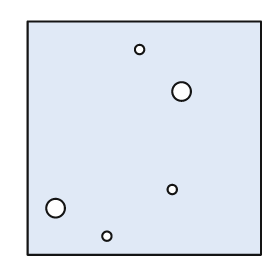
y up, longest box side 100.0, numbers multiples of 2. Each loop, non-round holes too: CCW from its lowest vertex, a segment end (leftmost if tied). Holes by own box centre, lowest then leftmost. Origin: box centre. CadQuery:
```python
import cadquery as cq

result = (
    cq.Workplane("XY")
    .moveTo(-50.0, -50.0)
    .lineTo(50.0, -50.0)
    .lineTo(50.0, 50.0)
    .lineTo(-50.0, 50.0)
    .close()
    .moveTo(-16.0, -42.0)
    .circle(2.0)
    .moveTo(-38.0, -30.0)
    .circle(4.0)
    .moveTo(12.0, -22.0)
    .circle(2.0)
    .moveTo(16.0, 20.0)
    .circle(4.0)
    .moveTo(-2.0, 38.0)
    .circle(2.0)
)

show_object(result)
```